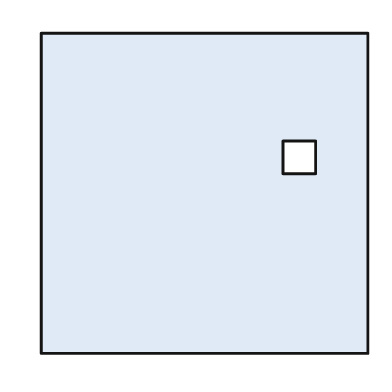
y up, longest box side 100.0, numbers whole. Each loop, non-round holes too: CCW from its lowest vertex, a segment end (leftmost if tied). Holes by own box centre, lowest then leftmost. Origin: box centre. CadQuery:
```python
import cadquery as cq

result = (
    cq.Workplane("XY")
    .moveTo(-50.0, -49.0)
    .lineTo(50.0, -49.0)
    .lineTo(50.0, 49.0)
    .lineTo(-50.0, 49.0)
    .close()
    .moveTo(24.0, 6.0)
    .lineTo(34.0, 6.0)
    .lineTo(34.0, 16.0)
    .lineTo(24.0, 16.0)
    .close()
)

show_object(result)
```